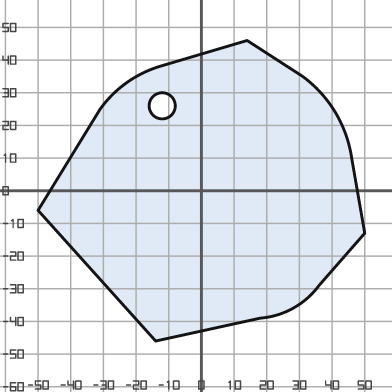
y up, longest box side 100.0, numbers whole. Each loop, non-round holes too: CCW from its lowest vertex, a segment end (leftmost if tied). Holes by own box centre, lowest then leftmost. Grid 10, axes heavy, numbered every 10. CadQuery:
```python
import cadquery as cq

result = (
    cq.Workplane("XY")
    .moveTo(-14.0, -46.0)
    .lineTo(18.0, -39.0)
    .threePointArc((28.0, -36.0), (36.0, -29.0))
    .lineTo(50.0, -13.0)
    .lineTo(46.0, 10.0)
    .threePointArc((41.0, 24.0), (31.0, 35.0))
    .lineTo(14.0, 46.0)
    .lineTo(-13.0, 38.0)
    .threePointArc((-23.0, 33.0), (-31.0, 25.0))
    .lineTo(-50.0, -6.0)
    .close()
    .moveTo(-12.0, 26.0)
    .circle(4.0)
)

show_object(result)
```